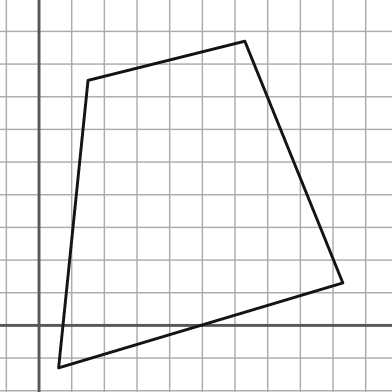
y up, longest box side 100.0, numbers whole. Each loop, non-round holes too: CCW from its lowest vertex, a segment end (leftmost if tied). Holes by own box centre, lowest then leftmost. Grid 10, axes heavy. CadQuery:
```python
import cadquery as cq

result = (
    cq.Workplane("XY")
    .moveTo(6.0, -13.0)
    .lineTo(93.0, 13.0)
    .lineTo(63.0, 87.0)
    .lineTo(15.0, 75.0)
    .close()
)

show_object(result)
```